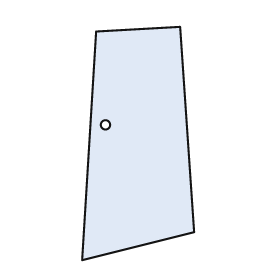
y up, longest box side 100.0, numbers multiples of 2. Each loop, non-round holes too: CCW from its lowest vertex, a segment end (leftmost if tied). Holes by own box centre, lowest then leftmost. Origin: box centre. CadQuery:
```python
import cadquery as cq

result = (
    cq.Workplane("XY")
    .moveTo(-24.0, -50.0)
    .lineTo(24.0, -38.0)
    .lineTo(18.0, 50.0)
    .lineTo(-18.0, 48.0)
    .close()
    .moveTo(-14.0, 8.0)
    .circle(2.0)
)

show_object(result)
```